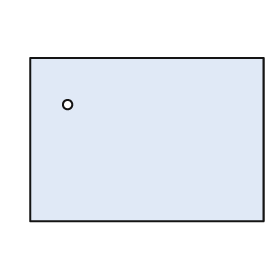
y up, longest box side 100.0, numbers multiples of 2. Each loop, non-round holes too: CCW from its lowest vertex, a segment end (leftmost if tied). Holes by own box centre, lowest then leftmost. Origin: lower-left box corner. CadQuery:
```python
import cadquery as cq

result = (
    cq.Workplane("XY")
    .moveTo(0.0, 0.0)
    .lineTo(100.0, 0.0)
    .lineTo(100.0, 70.0)
    .lineTo(0.0, 70.0)
    .close()
    .moveTo(16.0, 50.0)
    .circle(2.0)
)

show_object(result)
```